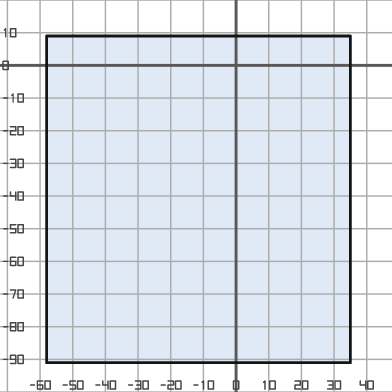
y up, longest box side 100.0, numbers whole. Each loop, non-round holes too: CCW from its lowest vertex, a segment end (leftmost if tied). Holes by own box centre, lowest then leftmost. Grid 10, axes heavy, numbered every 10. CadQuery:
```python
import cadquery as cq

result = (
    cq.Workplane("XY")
    .moveTo(-58.0, -91.0)
    .lineTo(35.0, -91.0)
    .lineTo(35.0, 9.0)
    .lineTo(-58.0, 9.0)
    .close()
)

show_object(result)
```